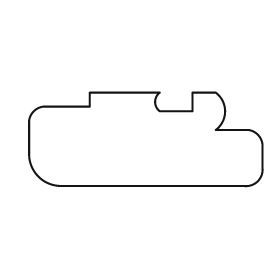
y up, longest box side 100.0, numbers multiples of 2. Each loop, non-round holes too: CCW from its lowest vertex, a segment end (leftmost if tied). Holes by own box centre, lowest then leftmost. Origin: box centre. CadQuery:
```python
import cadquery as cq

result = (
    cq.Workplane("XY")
    .moveTo(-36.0, -20.0)
    .lineTo(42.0, -20.0)
    .threePointArc((48.0, -18.0), (50.0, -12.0))
    .lineTo(50.0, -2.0)
    .threePointArc((48.0, 2.0), (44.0, 4.0))
    .lineTo(30.0, 4.0)
    .threePointArc((34.0, 12.0), (30.0, 20.0))
    .lineTo(20.0, 20.0)
    .lineTo(20.0, 12.0)
    .lineTo(6.0, 12.0)
    .threePointArc((4.0, 16.0), (6.0, 20.0))
    .lineTo(-24.0, 20.0)
    .lineTo(-24.0, 14.0)
    .lineTo(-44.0, 14.0)
    .threePointArc((-48.0, 12.0), (-50.0, 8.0))
    .lineTo(-50.0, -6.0)
    .threePointArc((-46.0, -16.0), (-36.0, -20.0))
    .close()
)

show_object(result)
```